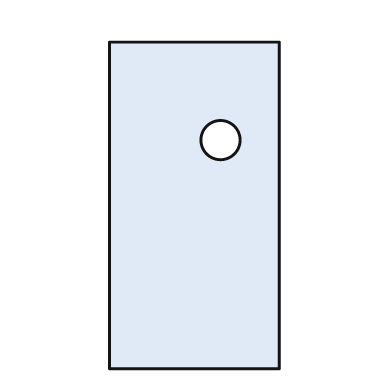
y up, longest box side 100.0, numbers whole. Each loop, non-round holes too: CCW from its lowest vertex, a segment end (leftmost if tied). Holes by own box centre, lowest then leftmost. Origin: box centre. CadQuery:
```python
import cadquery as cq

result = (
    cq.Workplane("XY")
    .moveTo(-26.0, -50.0)
    .lineTo(26.0, -50.0)
    .lineTo(26.0, 50.0)
    .lineTo(-26.0, 50.0)
    .close()
    .moveTo(8.0, 20.0)
    .circle(6.0)
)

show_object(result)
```